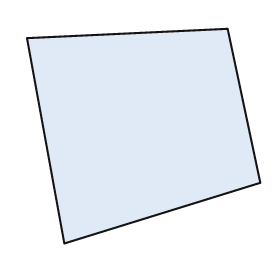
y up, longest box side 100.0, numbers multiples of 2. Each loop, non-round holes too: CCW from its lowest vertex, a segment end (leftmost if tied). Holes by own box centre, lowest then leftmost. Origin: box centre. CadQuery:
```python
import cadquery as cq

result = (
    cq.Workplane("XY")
    .moveTo(-34.0, -46.0)
    .lineTo(50.0, -20.0)
    .lineTo(36.0, 46.0)
    .lineTo(-50.0, 42.0)
    .close()
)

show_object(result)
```